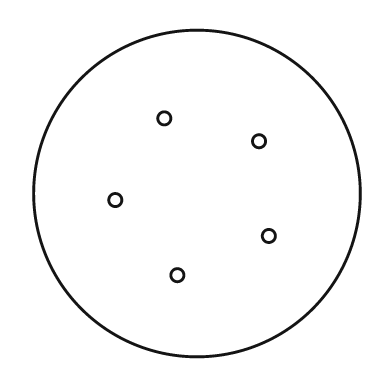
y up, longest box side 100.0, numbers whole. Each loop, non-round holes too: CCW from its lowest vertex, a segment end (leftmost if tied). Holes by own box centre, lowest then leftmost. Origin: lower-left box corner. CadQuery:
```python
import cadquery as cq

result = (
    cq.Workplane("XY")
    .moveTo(50.0, 50.0)
    .circle(50.0)
    .moveTo(44.0, 25.0)
    .circle(2.0)
    .moveTo(72.0, 37.0)
    .circle(2.0)
    .moveTo(25.0, 48.0)
    .circle(2.0)
    .moveTo(69.0, 66.0)
    .circle(2.0)
    .moveTo(40.0, 73.0)
    .circle(2.0)
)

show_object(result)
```